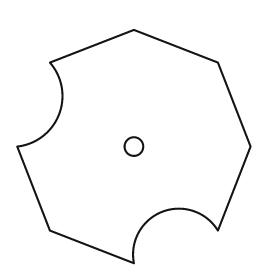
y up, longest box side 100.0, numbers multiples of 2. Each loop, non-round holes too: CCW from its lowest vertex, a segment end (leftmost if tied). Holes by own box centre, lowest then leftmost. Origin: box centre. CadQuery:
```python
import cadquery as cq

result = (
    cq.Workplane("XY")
    .moveTo(0.0, -50.0)
    .threePointArc((12.0, -28.0), (36.0, -36.0))
    .lineTo(50.0, 0.0)
    .lineTo(36.0, 36.0)
    .lineTo(0.0, 50.0)
    .lineTo(-36.0, 36.0)
    .threePointArc((-32.0, 14.0), (-50.0, 0.0))
    .lineTo(-36.0, -36.0)
    .close()
    .moveTo(0.0, 0.0)
    .circle(4.0)
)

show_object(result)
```